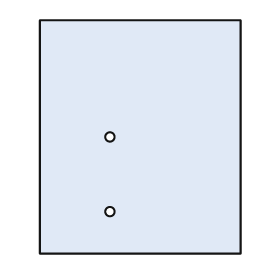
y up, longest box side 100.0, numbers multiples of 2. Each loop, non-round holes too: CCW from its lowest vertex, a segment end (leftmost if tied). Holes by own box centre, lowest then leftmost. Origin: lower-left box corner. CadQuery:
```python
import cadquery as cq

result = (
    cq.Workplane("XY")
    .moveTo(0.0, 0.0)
    .lineTo(86.0, 0.0)
    .lineTo(86.0, 100.0)
    .lineTo(0.0, 100.0)
    .close()
    .moveTo(30.0, 18.0)
    .circle(2.0)
    .moveTo(30.0, 50.0)
    .circle(2.0)
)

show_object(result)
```